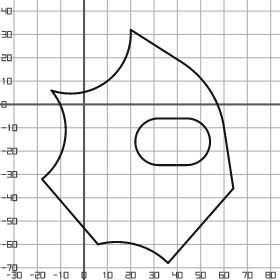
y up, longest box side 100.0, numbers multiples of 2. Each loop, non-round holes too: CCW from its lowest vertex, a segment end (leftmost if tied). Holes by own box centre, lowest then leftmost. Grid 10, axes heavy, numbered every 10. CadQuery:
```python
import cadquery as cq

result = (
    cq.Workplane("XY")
    .moveTo(36.0, -68.0)
    .lineTo(64.0, -36.0)
    .lineTo(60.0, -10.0)
    .threePointArc((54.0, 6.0), (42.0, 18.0))
    .lineTo(20.0, 32.0)
    .threePointArc((10.0, 10.0), (-14.0, 6.0))
    .threePointArc((-8.0, -14.0), (-18.0, -32.0))
    .lineTo(6.0, -60.0)
    .threePointArc((22.0, -60.0), (36.0, -68.0))
    .close()
    .moveTo(32.0, -26.0)
    .lineTo(44.0, -26.0)
    .threePointArc((54.0, -16.0), (44.0, -6.0))
    .lineTo(32.0, -6.0)
    .threePointArc((22.0, -16.0), (32.0, -26.0))
    .close()
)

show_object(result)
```